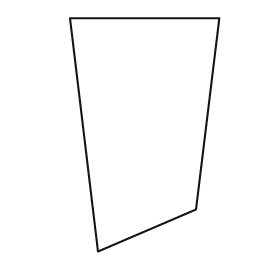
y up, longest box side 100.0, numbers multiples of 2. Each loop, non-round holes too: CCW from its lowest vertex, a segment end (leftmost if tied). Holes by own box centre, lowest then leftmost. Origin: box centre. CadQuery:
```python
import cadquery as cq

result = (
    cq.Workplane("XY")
    .moveTo(-20.0, -50.0)
    .lineTo(22.0, -32.0)
    .lineTo(32.0, 50.0)
    .lineTo(-32.0, 50.0)
    .close()
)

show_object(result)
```